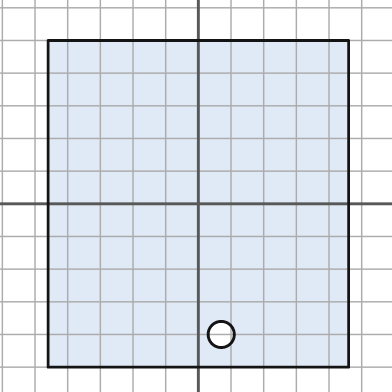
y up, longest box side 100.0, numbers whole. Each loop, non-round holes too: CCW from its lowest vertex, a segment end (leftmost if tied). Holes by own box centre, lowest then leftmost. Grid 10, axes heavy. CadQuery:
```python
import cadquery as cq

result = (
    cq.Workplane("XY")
    .moveTo(-46.0, -50.0)
    .lineTo(46.0, -50.0)
    .lineTo(46.0, 50.0)
    .lineTo(-46.0, 50.0)
    .close()
    .moveTo(7.0, -40.0)
    .circle(4.0)
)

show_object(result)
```